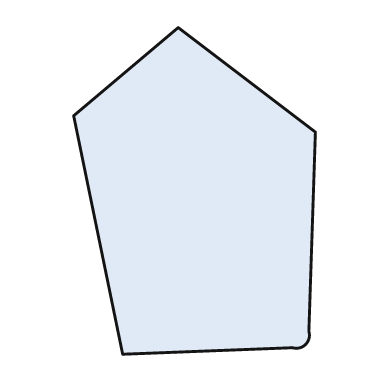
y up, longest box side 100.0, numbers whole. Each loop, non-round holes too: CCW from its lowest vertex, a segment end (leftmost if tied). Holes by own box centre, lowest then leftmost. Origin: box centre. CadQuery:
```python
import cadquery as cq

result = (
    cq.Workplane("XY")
    .moveTo(-22.0, -50.0)
    .lineTo(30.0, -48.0)
    .threePointArc((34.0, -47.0), (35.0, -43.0))
    .lineTo(37.0, 18.0)
    .lineTo(-5.0, 50.0)
    .lineTo(-37.0, 23.0)
    .close()
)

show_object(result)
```